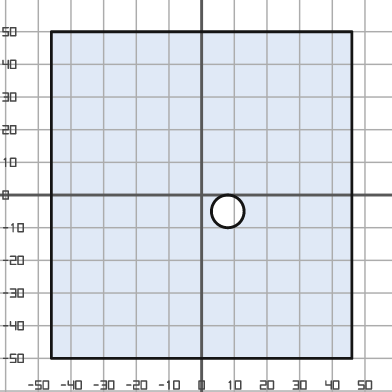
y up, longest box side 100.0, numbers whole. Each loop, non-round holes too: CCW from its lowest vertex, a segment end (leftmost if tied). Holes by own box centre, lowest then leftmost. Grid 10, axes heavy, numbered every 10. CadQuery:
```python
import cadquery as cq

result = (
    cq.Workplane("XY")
    .moveTo(-46.0, -50.0)
    .lineTo(46.0, -50.0)
    .lineTo(46.0, 50.0)
    .lineTo(-46.0, 50.0)
    .close()
    .moveTo(8.0, -5.0)
    .circle(5.0)
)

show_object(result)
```